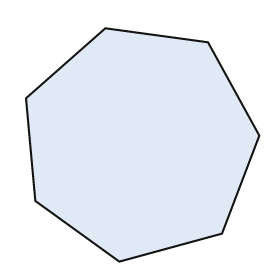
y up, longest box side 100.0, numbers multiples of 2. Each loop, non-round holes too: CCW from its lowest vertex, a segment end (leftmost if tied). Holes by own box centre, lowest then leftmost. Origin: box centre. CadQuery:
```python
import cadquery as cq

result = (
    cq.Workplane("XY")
    .moveTo(-10.0, -50.0)
    .lineTo(34.0, -38.0)
    .lineTo(50.0, 4.0)
    .lineTo(28.0, 44.0)
    .lineTo(-16.0, 50.0)
    .lineTo(-50.0, 20.0)
    .lineTo(-46.0, -24.0)
    .close()
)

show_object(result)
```